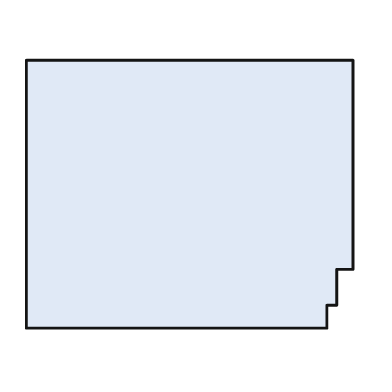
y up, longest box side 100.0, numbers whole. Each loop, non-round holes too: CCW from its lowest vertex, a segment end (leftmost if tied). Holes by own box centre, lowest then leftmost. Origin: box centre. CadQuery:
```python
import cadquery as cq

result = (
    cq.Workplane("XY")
    .moveTo(-50.0, -41.0)
    .lineTo(42.0, -41.0)
    .lineTo(42.0, -34.0)
    .lineTo(45.0, -34.0)
    .lineTo(45.0, -23.0)
    .lineTo(50.0, -23.0)
    .lineTo(50.0, 41.0)
    .lineTo(-50.0, 41.0)
    .close()
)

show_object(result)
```